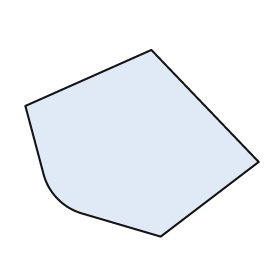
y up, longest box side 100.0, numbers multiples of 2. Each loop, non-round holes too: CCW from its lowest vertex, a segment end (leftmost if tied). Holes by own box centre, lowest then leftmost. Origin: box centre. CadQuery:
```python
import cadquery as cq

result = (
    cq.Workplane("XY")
    .moveTo(8.0, -40.0)
    .lineTo(50.0, -8.0)
    .lineTo(4.0, 40.0)
    .lineTo(-50.0, 16.0)
    .lineTo(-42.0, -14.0)
    .threePointArc((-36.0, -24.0), (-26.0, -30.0))
    .close()
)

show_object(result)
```